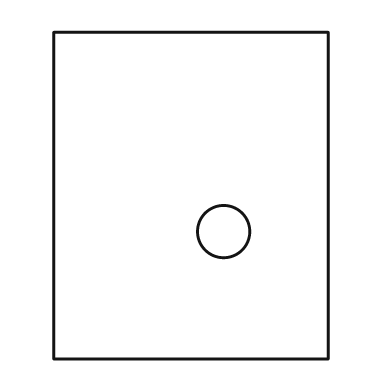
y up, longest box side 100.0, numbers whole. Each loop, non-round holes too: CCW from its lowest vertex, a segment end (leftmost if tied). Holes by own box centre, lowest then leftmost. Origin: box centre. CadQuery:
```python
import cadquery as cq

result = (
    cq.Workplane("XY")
    .moveTo(-42.0, -50.0)
    .lineTo(42.0, -50.0)
    .lineTo(42.0, 50.0)
    .lineTo(-42.0, 50.0)
    .close()
    .moveTo(10.0, -11.0)
    .circle(8.0)
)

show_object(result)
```